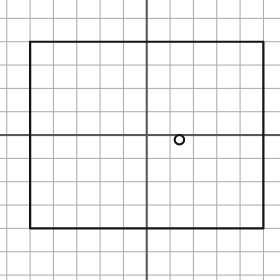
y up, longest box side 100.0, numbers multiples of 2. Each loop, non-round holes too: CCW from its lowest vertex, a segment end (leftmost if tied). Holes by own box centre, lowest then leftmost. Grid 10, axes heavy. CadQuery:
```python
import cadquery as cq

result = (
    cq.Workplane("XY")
    .moveTo(-50.0, -40.0)
    .lineTo(50.0, -40.0)
    .lineTo(50.0, 40.0)
    .lineTo(-50.0, 40.0)
    .close()
    .moveTo(14.0, -2.0)
    .circle(2.0)
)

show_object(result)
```